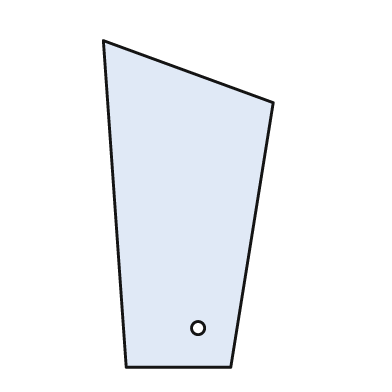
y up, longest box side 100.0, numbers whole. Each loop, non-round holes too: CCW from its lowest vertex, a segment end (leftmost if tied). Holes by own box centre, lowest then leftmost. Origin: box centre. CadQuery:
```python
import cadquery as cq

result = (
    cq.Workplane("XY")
    .moveTo(-19.0, -50.0)
    .lineTo(13.0, -50.0)
    .lineTo(26.0, 31.0)
    .lineTo(-26.0, 50.0)
    .close()
    .moveTo(3.0, -38.0)
    .circle(2.0)
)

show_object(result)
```